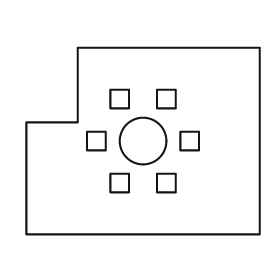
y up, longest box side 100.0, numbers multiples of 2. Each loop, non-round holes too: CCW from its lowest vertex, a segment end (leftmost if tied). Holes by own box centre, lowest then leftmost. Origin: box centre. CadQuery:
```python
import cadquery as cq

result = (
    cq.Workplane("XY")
    .moveTo(-50.0, -40.0)
    .lineTo(50.0, -40.0)
    .lineTo(50.0, 40.0)
    .lineTo(-28.0, 40.0)
    .lineTo(-28.0, 8.0)
    .lineTo(-50.0, 8.0)
    .close()
    .moveTo(-14.0, -22.0)
    .lineTo(-6.0, -22.0)
    .lineTo(-6.0, -14.0)
    .lineTo(-14.0, -14.0)
    .close()
    .moveTo(6.0, -22.0)
    .lineTo(14.0, -22.0)
    .lineTo(14.0, -14.0)
    .lineTo(6.0, -14.0)
    .close()
    .moveTo(-24.0, -4.0)
    .lineTo(-16.0, -4.0)
    .lineTo(-16.0, 4.0)
    .lineTo(-24.0, 4.0)
    .close()
    .moveTo(0.0, 0.0)
    .circle(10.0)
    .moveTo(16.0, -4.0)
    .lineTo(24.0, -4.0)
    .lineTo(24.0, 4.0)
    .lineTo(16.0, 4.0)
    .close()
    .moveTo(-14.0, 14.0)
    .lineTo(-6.0, 14.0)
    .lineTo(-6.0, 22.0)
    .lineTo(-14.0, 22.0)
    .close()
    .moveTo(6.0, 14.0)
    .lineTo(14.0, 14.0)
    .lineTo(14.0, 22.0)
    .lineTo(6.0, 22.0)
    .close()
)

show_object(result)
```